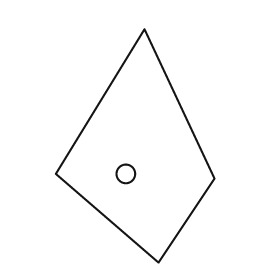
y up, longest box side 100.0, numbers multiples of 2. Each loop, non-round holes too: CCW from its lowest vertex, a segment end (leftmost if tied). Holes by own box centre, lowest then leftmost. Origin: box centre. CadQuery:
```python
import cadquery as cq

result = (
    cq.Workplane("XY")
    .moveTo(10.0, -50.0)
    .lineTo(34.0, -14.0)
    .lineTo(4.0, 50.0)
    .lineTo(-34.0, -12.0)
    .close()
    .moveTo(-4.0, -12.0)
    .circle(4.0)
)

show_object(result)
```